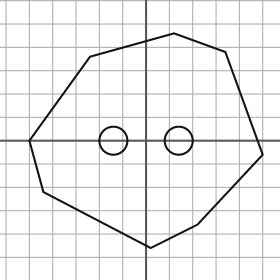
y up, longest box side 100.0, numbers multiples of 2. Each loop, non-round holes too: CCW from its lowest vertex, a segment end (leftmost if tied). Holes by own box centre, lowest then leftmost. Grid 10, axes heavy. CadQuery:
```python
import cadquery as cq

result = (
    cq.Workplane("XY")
    .moveTo(2.0, -46.0)
    .lineTo(22.0, -36.0)
    .lineTo(50.0, -6.0)
    .lineTo(34.0, 38.0)
    .lineTo(12.0, 46.0)
    .lineTo(-24.0, 36.0)
    .lineTo(-50.0, 0.0)
    .lineTo(-44.0, -22.0)
    .close()
    .moveTo(-14.0, 0.0)
    .circle(6.0)
    .moveTo(14.0, 0.0)
    .circle(6.0)
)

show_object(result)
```